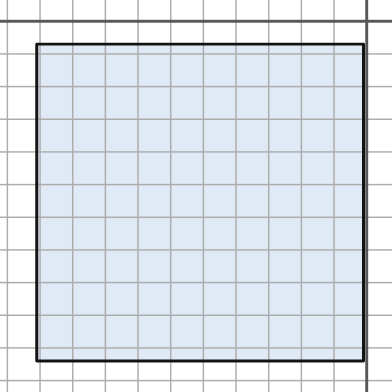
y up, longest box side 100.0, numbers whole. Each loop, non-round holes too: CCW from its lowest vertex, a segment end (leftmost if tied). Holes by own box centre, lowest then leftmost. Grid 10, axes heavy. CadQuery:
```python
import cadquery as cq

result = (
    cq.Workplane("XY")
    .moveTo(-101.0, -104.0)
    .lineTo(-1.0, -104.0)
    .lineTo(-1.0, -7.0)
    .lineTo(-101.0, -7.0)
    .close()
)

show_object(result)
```